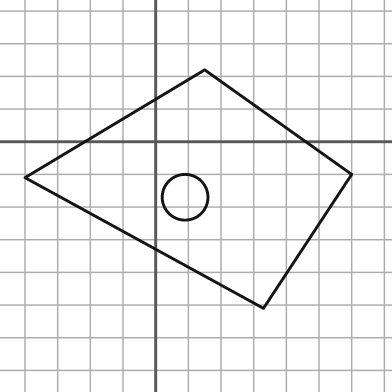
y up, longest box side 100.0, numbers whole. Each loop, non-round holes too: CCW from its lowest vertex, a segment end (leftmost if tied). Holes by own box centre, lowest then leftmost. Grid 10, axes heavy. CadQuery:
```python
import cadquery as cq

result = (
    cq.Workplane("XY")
    .moveTo(33.0, -51.0)
    .lineTo(60.0, -10.0)
    .lineTo(15.0, 22.0)
    .lineTo(-40.0, -11.0)
    .close()
    .moveTo(9.0, -17.0)
    .circle(7.0)
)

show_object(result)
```